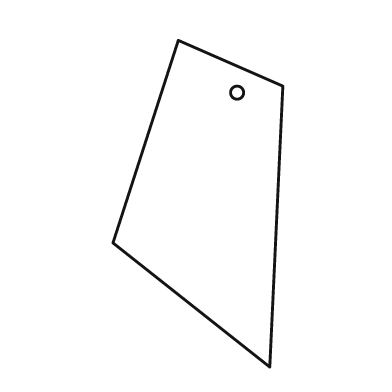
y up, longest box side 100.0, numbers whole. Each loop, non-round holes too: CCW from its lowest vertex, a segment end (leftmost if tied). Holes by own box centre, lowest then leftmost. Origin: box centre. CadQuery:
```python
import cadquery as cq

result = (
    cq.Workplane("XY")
    .moveTo(22.0, -50.0)
    .lineTo(26.0, 36.0)
    .lineTo(-6.0, 50.0)
    .lineTo(-26.0, -12.0)
    .close()
    .moveTo(12.0, 34.0)
    .circle(2.0)
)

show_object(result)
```